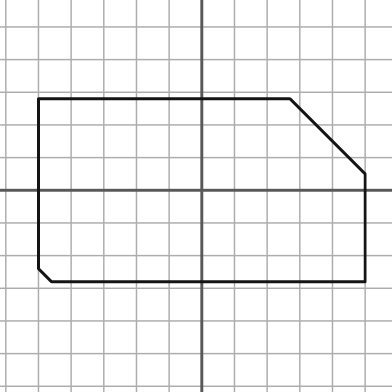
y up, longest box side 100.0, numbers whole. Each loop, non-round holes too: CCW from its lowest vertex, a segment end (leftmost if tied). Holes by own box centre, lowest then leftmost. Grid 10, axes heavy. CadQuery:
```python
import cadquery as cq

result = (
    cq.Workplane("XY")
    .moveTo(-46.0, -28.0)
    .lineTo(50.0, -28.0)
    .lineTo(50.0, 5.0)
    .lineTo(27.0, 28.0)
    .lineTo(-50.0, 28.0)
    .lineTo(-50.0, -24.0)
    .close()
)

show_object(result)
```